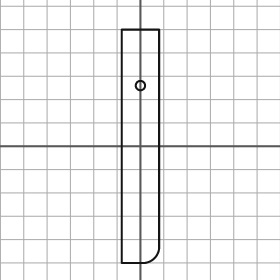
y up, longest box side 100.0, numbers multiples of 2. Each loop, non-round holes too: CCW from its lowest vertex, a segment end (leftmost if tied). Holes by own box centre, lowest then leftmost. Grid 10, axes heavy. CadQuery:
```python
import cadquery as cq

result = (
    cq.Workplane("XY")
    .moveTo(-8.0, -50.0)
    .lineTo(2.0, -50.0)
    .threePointArc((6.0, -48.0), (8.0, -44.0))
    .lineTo(8.0, 50.0)
    .lineTo(-8.0, 50.0)
    .close()
    .moveTo(0.0, 26.0)
    .circle(2.0)
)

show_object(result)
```